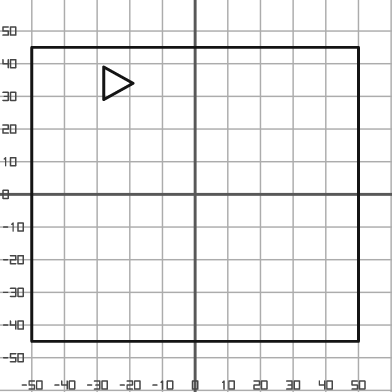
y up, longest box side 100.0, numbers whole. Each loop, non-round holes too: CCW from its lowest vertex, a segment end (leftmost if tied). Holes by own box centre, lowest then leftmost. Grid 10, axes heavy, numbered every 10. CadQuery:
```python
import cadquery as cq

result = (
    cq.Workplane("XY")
    .moveTo(-50.0, -45.0)
    .lineTo(50.0, -45.0)
    .lineTo(50.0, 45.0)
    .lineTo(-50.0, 45.0)
    .close()
    .moveTo(-28.0, 29.0)
    .lineTo(-19.0, 34.0)
    .lineTo(-28.0, 39.0)
    .close()
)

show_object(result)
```